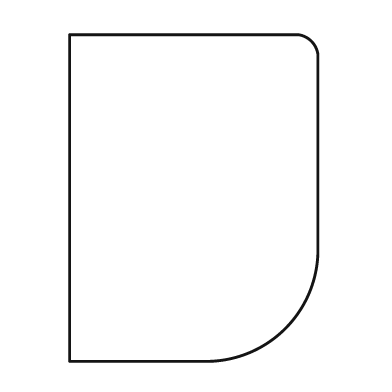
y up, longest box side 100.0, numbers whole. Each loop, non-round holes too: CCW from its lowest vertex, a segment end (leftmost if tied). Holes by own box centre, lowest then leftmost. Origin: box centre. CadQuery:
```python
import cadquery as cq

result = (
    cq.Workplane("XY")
    .moveTo(-38.0, -50.0)
    .lineTo(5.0, -50.0)
    .threePointArc((28.0, -40.0), (38.0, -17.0))
    .lineTo(38.0, 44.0)
    .threePointArc((36.0, 48.0), (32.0, 50.0))
    .lineTo(-38.0, 50.0)
    .close()
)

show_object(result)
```